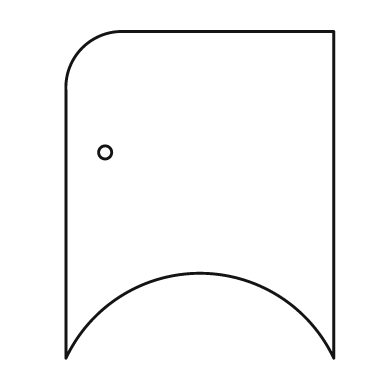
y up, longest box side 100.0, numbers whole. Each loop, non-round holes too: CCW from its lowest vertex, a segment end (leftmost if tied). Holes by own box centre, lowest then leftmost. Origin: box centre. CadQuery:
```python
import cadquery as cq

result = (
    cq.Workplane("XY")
    .moveTo(-41.0, -50.0)
    .threePointArc((0.0, -24.0), (41.0, -50.0))
    .lineTo(41.0, 50.0)
    .lineTo(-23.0, 50.0)
    .threePointArc((-36.0, 45.0), (-41.0, 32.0))
    .close()
    .moveTo(-29.0, 13.0)
    .circle(2.0)
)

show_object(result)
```